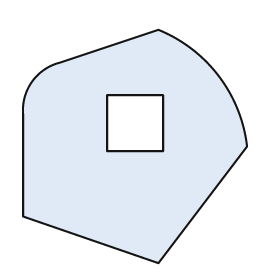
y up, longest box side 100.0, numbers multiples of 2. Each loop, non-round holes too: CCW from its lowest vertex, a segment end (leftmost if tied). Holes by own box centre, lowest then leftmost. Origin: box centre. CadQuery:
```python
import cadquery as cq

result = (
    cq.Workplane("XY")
    .moveTo(10.0, -50.0)
    .lineTo(48.0, 0.0)
    .threePointArc((36.0, 30.0), (10.0, 50.0))
    .lineTo(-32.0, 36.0)
    .threePointArc((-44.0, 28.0), (-48.0, 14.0))
    .lineTo(-48.0, -30.0)
    .close()
    .moveTo(-12.0, -2.0)
    .lineTo(12.0, -2.0)
    .lineTo(12.0, 22.0)
    .lineTo(-12.0, 22.0)
    .close()
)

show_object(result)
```